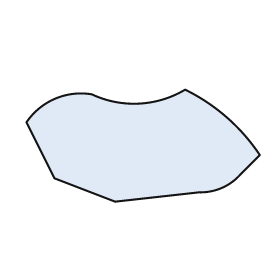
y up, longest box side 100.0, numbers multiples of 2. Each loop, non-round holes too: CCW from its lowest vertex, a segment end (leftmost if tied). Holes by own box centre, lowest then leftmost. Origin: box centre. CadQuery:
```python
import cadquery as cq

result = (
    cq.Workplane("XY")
    .moveTo(-12.0, -24.0)
    .lineTo(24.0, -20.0)
    .threePointArc((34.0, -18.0), (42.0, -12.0))
    .lineTo(50.0, -4.0)
    .threePointArc((36.0, 12.0), (18.0, 24.0))
    .threePointArc((-2.0, 18.0), (-22.0, 22.0))
    .threePointArc((-38.0, 20.0), (-50.0, 10.0))
    .lineTo(-38.0, -14.0)
    .close()
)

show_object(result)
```